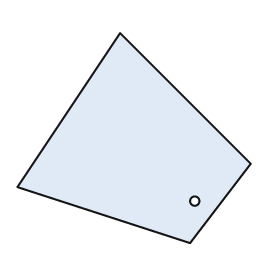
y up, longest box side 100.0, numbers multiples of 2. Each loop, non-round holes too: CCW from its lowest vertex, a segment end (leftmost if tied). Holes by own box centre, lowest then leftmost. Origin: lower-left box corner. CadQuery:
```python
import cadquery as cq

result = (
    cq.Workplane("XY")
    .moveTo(74.0, 0.0)
    .lineTo(100.0, 34.0)
    .lineTo(44.0, 90.0)
    .lineTo(0.0, 24.0)
    .close()
    .moveTo(76.0, 18.0)
    .circle(2.0)
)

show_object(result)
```